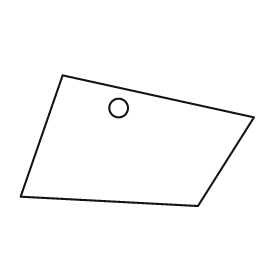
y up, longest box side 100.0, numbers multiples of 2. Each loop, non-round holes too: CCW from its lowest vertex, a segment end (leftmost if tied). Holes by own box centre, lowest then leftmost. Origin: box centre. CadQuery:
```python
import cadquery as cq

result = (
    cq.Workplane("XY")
    .moveTo(26.0, -28.0)
    .lineTo(50.0, 10.0)
    .lineTo(-32.0, 28.0)
    .lineTo(-50.0, -24.0)
    .close()
    .moveTo(-8.0, 14.0)
    .circle(4.0)
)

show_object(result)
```